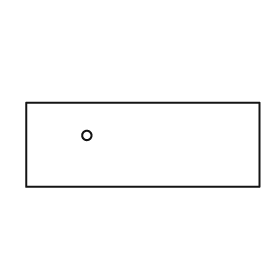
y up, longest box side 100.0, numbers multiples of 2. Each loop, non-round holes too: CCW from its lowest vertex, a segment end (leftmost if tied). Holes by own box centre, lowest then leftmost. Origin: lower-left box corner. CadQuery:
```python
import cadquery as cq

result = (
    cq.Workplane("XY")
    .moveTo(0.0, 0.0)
    .lineTo(100.0, 0.0)
    .lineTo(100.0, 36.0)
    .lineTo(0.0, 36.0)
    .close()
    .moveTo(26.0, 22.0)
    .circle(2.0)
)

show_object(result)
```